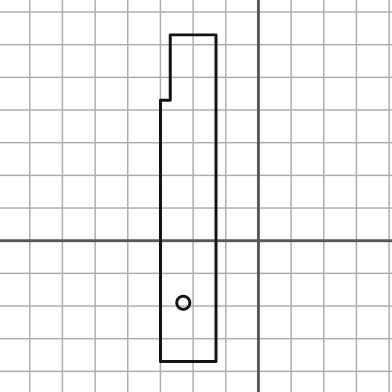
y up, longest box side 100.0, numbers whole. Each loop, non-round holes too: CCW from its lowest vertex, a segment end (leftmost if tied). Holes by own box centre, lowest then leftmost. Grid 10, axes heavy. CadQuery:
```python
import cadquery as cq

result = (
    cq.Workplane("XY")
    .moveTo(-30.0, -37.0)
    .lineTo(-13.0, -37.0)
    .lineTo(-13.0, 63.0)
    .lineTo(-27.0, 63.0)
    .lineTo(-27.0, 43.0)
    .lineTo(-30.0, 43.0)
    .close()
    .moveTo(-23.0, -19.0)
    .circle(2.0)
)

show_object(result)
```